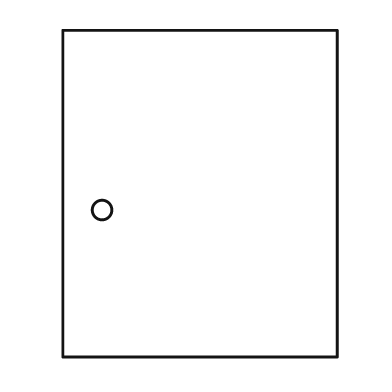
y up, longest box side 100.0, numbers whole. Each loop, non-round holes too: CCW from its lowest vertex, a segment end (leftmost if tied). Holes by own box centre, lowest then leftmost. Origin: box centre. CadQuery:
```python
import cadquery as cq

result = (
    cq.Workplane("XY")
    .moveTo(-42.0, -50.0)
    .lineTo(42.0, -50.0)
    .lineTo(42.0, 50.0)
    .lineTo(-42.0, 50.0)
    .close()
    .moveTo(-30.0, -5.0)
    .circle(3.0)
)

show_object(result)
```